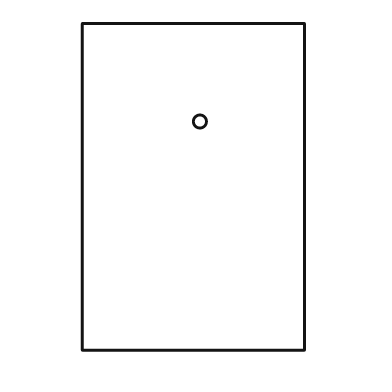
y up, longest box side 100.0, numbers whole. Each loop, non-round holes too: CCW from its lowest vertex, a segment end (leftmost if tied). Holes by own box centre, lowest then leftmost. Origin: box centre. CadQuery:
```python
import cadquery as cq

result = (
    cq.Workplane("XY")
    .moveTo(-34.0, -50.0)
    .lineTo(34.0, -50.0)
    .lineTo(34.0, 50.0)
    .lineTo(-34.0, 50.0)
    .close()
    .moveTo(2.0, 20.0)
    .circle(2.0)
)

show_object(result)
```